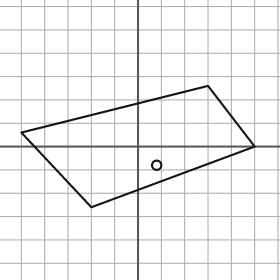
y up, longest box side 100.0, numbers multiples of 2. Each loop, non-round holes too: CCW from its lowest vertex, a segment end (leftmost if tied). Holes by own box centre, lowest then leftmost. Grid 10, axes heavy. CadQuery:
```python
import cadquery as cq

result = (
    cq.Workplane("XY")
    .moveTo(-20.0, -26.0)
    .lineTo(50.0, 0.0)
    .lineTo(30.0, 26.0)
    .lineTo(-50.0, 6.0)
    .close()
    .moveTo(8.0, -8.0)
    .circle(2.0)
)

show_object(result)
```